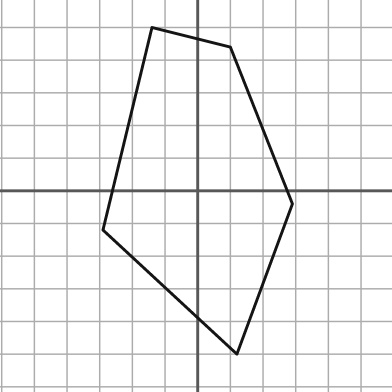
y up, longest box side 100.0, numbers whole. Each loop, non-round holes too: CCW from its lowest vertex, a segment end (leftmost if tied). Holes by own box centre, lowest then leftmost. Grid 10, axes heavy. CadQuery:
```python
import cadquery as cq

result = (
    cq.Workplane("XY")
    .moveTo(12.0, -50.0)
    .lineTo(29.0, -4.0)
    .lineTo(10.0, 44.0)
    .lineTo(-14.0, 50.0)
    .lineTo(-29.0, -12.0)
    .close()
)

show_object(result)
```